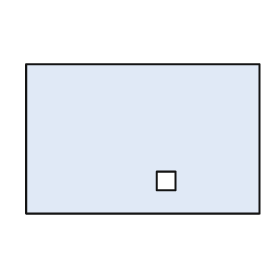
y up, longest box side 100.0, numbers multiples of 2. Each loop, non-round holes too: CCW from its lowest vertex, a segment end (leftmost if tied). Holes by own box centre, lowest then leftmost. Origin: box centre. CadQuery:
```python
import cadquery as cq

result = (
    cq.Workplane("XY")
    .moveTo(-50.0, -32.0)
    .lineTo(50.0, -32.0)
    .lineTo(50.0, 32.0)
    .lineTo(-50.0, 32.0)
    .close()
    .moveTo(6.0, -22.0)
    .lineTo(14.0, -22.0)
    .lineTo(14.0, -14.0)
    .lineTo(6.0, -14.0)
    .close()
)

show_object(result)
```